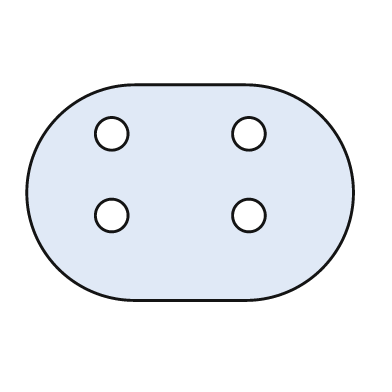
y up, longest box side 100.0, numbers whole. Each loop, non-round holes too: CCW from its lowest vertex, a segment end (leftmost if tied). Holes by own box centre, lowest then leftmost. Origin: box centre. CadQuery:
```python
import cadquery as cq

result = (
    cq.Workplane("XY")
    .moveTo(-17.0, -33.0)
    .lineTo(17.0, -33.0)
    .threePointArc((50.0, 0.0), (17.0, 33.0))
    .lineTo(-17.0, 33.0)
    .threePointArc((-50.0, 0.0), (-17.0, -33.0))
    .close()
    .moveTo(-24.0, -7.0)
    .circle(5.0)
    .moveTo(18.0, -7.0)
    .circle(5.0)
    .moveTo(-24.0, 18.0)
    .circle(5.0)
    .moveTo(18.0, 18.0)
    .circle(5.0)
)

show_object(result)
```